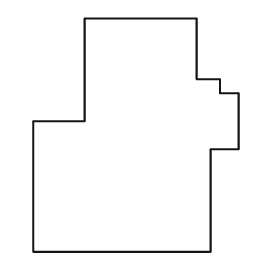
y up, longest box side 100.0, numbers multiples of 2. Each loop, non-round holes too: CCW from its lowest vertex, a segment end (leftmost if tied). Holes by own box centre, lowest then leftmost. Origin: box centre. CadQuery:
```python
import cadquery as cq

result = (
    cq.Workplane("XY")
    .moveTo(-44.0, -50.0)
    .lineTo(32.0, -50.0)
    .lineTo(32.0, -6.0)
    .lineTo(44.0, -6.0)
    .lineTo(44.0, 18.0)
    .lineTo(36.0, 18.0)
    .lineTo(36.0, 24.0)
    .lineTo(26.0, 24.0)
    .lineTo(26.0, 50.0)
    .lineTo(-22.0, 50.0)
    .lineTo(-22.0, 6.0)
    .lineTo(-44.0, 6.0)
    .close()
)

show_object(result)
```